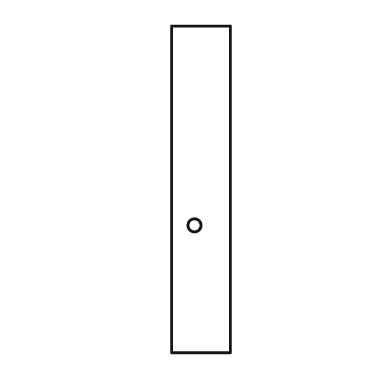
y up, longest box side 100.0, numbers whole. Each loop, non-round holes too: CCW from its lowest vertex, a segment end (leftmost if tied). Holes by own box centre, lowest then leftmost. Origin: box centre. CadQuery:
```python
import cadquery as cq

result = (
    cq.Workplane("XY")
    .moveTo(-9.0, -50.0)
    .lineTo(9.0, -50.0)
    .lineTo(9.0, 50.0)
    .lineTo(-9.0, 50.0)
    .close()
    .moveTo(-2.0, -11.0)
    .circle(2.0)
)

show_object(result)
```